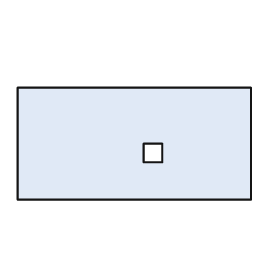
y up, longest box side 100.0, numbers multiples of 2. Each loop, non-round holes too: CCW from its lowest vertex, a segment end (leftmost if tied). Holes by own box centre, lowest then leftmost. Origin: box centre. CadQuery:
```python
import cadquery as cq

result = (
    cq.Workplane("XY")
    .moveTo(-50.0, -24.0)
    .lineTo(50.0, -24.0)
    .lineTo(50.0, 24.0)
    .lineTo(-50.0, 24.0)
    .close()
    .moveTo(4.0, -8.0)
    .lineTo(12.0, -8.0)
    .lineTo(12.0, 0.0)
    .lineTo(4.0, 0.0)
    .close()
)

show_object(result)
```